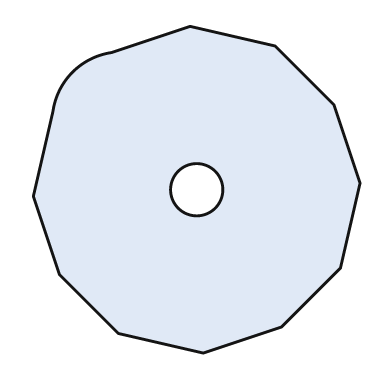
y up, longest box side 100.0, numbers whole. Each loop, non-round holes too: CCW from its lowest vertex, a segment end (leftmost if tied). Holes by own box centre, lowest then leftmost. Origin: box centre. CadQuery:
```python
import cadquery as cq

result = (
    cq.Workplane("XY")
    .moveTo(2.0, -50.0)
    .lineTo(26.0, -42.0)
    .lineTo(44.0, -24.0)
    .lineTo(50.0, 2.0)
    .lineTo(42.0, 26.0)
    .lineTo(24.0, 44.0)
    .lineTo(-2.0, 50.0)
    .lineTo(-26.0, 42.0)
    .threePointArc((-38.0, 36.0), (-44.0, 24.0))
    .lineTo(-50.0, -2.0)
    .lineTo(-42.0, -26.0)
    .lineTo(-24.0, -44.0)
    .close()
    .moveTo(0.0, 0.0)
    .circle(8.0)
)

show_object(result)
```